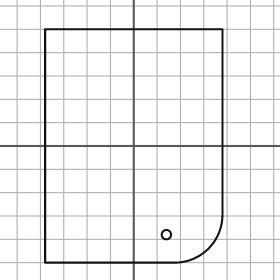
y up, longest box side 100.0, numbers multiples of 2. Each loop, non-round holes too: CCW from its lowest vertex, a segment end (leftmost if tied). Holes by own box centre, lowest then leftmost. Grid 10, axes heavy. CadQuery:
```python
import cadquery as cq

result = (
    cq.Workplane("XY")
    .moveTo(-38.0, -50.0)
    .lineTo(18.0, -50.0)
    .threePointArc((32.0, -44.0), (38.0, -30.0))
    .lineTo(38.0, 50.0)
    .lineTo(-38.0, 50.0)
    .close()
    .moveTo(14.0, -38.0)
    .circle(2.0)
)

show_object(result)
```